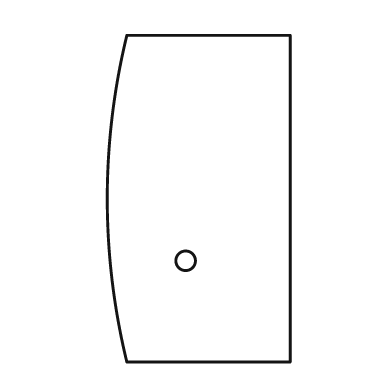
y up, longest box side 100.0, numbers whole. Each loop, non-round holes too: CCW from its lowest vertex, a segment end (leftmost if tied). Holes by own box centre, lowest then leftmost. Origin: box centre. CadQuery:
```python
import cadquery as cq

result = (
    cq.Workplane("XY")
    .moveTo(-22.0, -50.0)
    .lineTo(28.0, -50.0)
    .lineTo(28.0, 50.0)
    .lineTo(-22.0, 50.0)
    .threePointArc((-28.0, 0.0), (-22.0, -50.0))
    .close()
    .moveTo(-4.0, -19.0)
    .circle(3.0)
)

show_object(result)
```